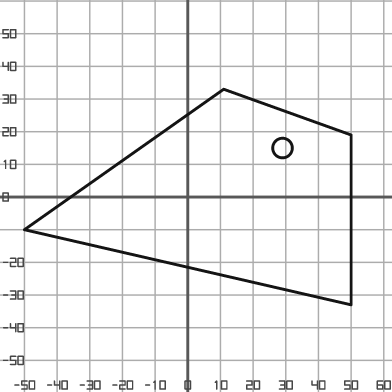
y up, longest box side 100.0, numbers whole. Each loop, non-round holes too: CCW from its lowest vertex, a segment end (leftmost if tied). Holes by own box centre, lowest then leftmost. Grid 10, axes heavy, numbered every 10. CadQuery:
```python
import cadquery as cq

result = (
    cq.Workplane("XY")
    .moveTo(50.0, -33.0)
    .lineTo(50.0, 19.0)
    .lineTo(11.0, 33.0)
    .lineTo(-50.0, -10.0)
    .close()
    .moveTo(29.0, 15.0)
    .circle(3.0)
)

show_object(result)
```